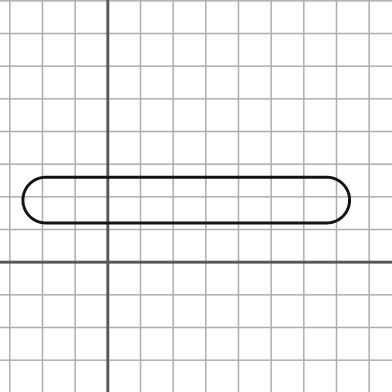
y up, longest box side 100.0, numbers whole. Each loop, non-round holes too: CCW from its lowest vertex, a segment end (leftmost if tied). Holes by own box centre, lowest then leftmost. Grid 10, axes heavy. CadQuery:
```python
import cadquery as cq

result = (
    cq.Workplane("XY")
    .moveTo(-19.0, 12.0)
    .lineTo(67.0, 12.0)
    .threePointArc((74.0, 19.0), (67.0, 26.0))
    .lineTo(-19.0, 26.0)
    .threePointArc((-26.0, 19.0), (-19.0, 12.0))
    .close()
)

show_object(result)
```